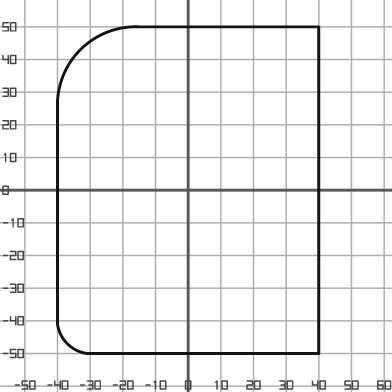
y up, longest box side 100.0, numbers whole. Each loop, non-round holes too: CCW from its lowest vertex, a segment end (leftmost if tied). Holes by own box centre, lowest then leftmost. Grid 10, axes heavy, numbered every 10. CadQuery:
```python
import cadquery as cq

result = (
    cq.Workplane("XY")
    .moveTo(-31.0, -50.0)
    .lineTo(40.0, -50.0)
    .lineTo(40.0, 50.0)
    .lineTo(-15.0, 50.0)
    .threePointArc((-33.0, 43.0), (-40.0, 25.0))
    .lineTo(-40.0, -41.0)
    .threePointArc((-37.0, -47.0), (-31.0, -50.0))
    .close()
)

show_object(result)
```